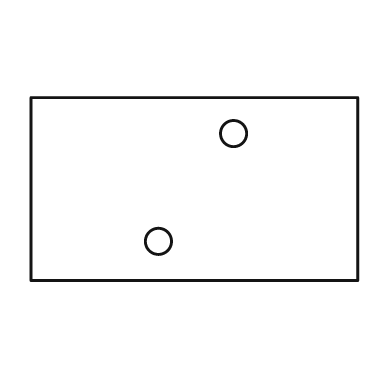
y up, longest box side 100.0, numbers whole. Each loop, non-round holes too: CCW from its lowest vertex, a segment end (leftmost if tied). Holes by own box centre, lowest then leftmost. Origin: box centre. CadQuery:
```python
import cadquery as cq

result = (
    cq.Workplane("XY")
    .moveTo(-50.0, -28.0)
    .lineTo(50.0, -28.0)
    .lineTo(50.0, 28.0)
    .lineTo(-50.0, 28.0)
    .close()
    .moveTo(-11.0, -16.0)
    .circle(4.0)
    .moveTo(12.0, 17.0)
    .circle(4.0)
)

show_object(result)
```